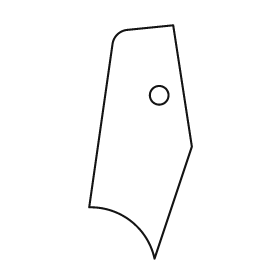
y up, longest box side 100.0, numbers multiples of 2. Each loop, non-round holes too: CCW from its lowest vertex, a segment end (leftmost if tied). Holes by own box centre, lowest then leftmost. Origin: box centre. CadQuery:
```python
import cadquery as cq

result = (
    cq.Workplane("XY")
    .moveTo(6.0, -50.0)
    .lineTo(22.0, -2.0)
    .lineTo(14.0, 50.0)
    .lineTo(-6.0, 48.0)
    .threePointArc((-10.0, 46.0), (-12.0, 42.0))
    .lineTo(-22.0, -28.0)
    .threePointArc((-4.0, -34.0), (6.0, -50.0))
    .close()
    .moveTo(8.0, 20.0)
    .circle(4.0)
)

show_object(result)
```